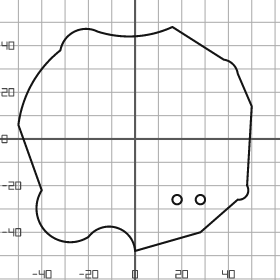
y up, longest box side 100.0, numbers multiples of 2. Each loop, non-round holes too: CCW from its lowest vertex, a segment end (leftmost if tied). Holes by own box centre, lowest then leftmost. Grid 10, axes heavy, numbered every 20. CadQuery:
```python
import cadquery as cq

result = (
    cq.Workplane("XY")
    .moveTo(0.0, -48.0)
    .lineTo(28.0, -40.0)
    .lineTo(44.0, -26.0)
    .threePointArc((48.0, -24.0), (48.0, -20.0))
    .lineTo(50.0, 14.0)
    .lineTo(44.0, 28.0)
    .threePointArc((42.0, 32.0), (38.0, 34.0))
    .lineTo(16.0, 48.0)
    .threePointArc((0.0, 44.0), (-16.0, 46.0))
    .threePointArc((-26.0, 46.0), (-32.0, 38.0))
    .threePointArc((-44.0, 24.0), (-50.0, 6.0))
    .lineTo(-40.0, -22.0)
    .threePointArc((-38.0, -40.0), (-20.0, -42.0))
    .threePointArc((-8.0, -38.0), (0.0, -48.0))
    .close()
    .moveTo(18.0, -26.0)
    .circle(2.0)
    .moveTo(28.0, -26.0)
    .circle(2.0)
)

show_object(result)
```